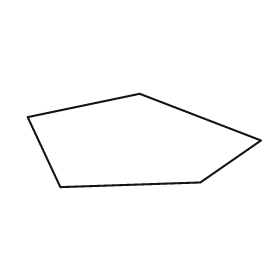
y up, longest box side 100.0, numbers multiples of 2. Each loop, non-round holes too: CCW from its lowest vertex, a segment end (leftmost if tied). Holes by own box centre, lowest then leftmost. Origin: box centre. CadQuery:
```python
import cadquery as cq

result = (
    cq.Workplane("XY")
    .moveTo(-36.0, -20.0)
    .lineTo(24.0, -18.0)
    .lineTo(50.0, 0.0)
    .lineTo(-2.0, 20.0)
    .lineTo(-50.0, 10.0)
    .close()
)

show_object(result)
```